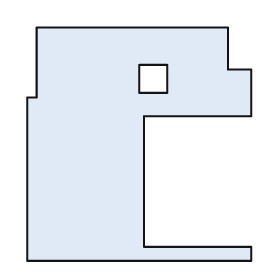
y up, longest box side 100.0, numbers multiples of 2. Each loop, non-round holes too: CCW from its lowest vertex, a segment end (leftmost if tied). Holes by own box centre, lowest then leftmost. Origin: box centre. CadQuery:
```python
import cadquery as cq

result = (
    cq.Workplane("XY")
    .moveTo(-48.0, -50.0)
    .lineTo(48.0, -50.0)
    .lineTo(48.0, -44.0)
    .lineTo(2.0, -44.0)
    .lineTo(2.0, 12.0)
    .lineTo(48.0, 12.0)
    .lineTo(48.0, 32.0)
    .lineTo(38.0, 32.0)
    .lineTo(38.0, 50.0)
    .lineTo(-44.0, 50.0)
    .lineTo(-44.0, 20.0)
    .lineTo(-48.0, 20.0)
    .close()
    .moveTo(0.0, 22.0)
    .lineTo(12.0, 22.0)
    .lineTo(12.0, 34.0)
    .lineTo(0.0, 34.0)
    .close()
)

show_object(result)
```